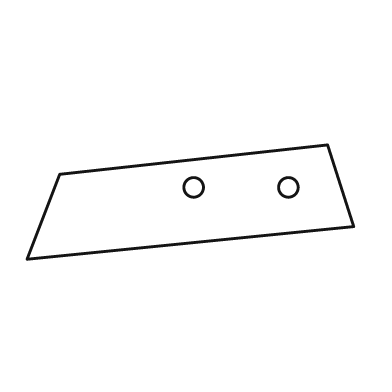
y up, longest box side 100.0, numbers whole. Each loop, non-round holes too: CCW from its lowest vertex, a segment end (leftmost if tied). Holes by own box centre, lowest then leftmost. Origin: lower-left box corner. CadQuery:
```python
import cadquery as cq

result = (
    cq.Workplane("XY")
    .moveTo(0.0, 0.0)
    .lineTo(100.0, 10.0)
    .lineTo(92.0, 35.0)
    .lineTo(10.0, 26.0)
    .close()
    .moveTo(51.0, 22.0)
    .circle(3.0)
    .moveTo(80.0, 22.0)
    .circle(3.0)
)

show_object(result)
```